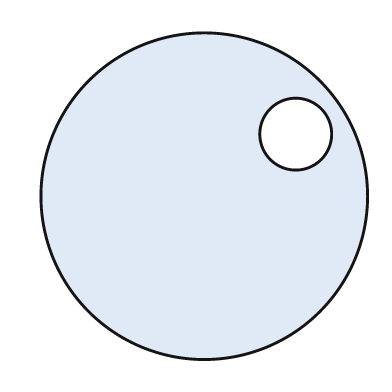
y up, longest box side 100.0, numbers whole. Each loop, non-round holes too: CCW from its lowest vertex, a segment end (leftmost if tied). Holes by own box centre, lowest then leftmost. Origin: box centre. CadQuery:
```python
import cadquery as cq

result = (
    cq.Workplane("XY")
    .moveTo(0.0, 0.0)
    .circle(50.0)
    .moveTo(28.0, 19.0)
    .circle(11.0)
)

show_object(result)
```